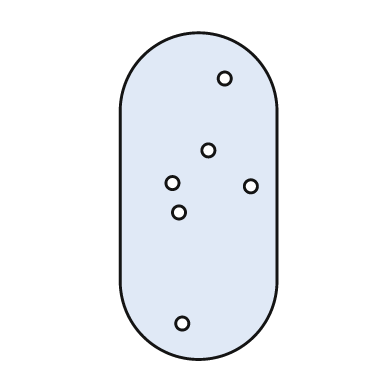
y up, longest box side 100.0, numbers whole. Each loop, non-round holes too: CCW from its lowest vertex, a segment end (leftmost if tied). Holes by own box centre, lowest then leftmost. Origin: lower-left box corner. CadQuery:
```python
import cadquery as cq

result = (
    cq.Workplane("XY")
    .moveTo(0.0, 24.0)
    .threePointArc((24.0, 0.0), (48.0, 24.0))
    .lineTo(48.0, 76.0)
    .threePointArc((24.0, 100.0), (0.0, 76.0))
    .close()
    .moveTo(19.0, 11.0)
    .circle(2.0)
    .moveTo(18.0, 45.0)
    .circle(2.0)
    .moveTo(40.0, 53.0)
    .circle(2.0)
    .moveTo(16.0, 54.0)
    .circle(2.0)
    .moveTo(27.0, 64.0)
    .circle(2.0)
    .moveTo(32.0, 86.0)
    .circle(2.0)
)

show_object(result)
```